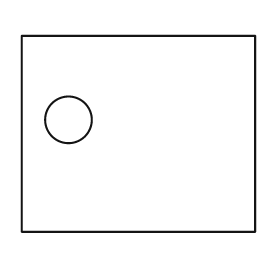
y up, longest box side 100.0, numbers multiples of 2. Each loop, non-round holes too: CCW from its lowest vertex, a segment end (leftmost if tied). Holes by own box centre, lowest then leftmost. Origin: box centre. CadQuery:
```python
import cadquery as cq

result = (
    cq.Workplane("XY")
    .moveTo(-50.0, -42.0)
    .lineTo(50.0, -42.0)
    .lineTo(50.0, 42.0)
    .lineTo(-50.0, 42.0)
    .close()
    .moveTo(-30.0, 6.0)
    .circle(10.0)
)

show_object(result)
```